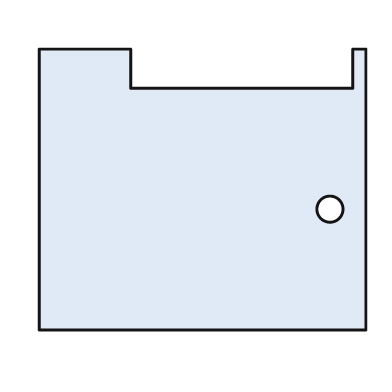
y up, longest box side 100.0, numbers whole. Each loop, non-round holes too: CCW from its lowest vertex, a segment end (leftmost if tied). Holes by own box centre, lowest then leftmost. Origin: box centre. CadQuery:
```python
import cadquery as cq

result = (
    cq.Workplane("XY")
    .moveTo(-50.0, -43.0)
    .lineTo(50.0, -43.0)
    .lineTo(50.0, 43.0)
    .lineTo(46.0, 43.0)
    .lineTo(46.0, 31.0)
    .lineTo(-22.0, 31.0)
    .lineTo(-22.0, 43.0)
    .lineTo(-50.0, 43.0)
    .close()
    .moveTo(39.0, -6.0)
    .circle(4.0)
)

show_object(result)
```